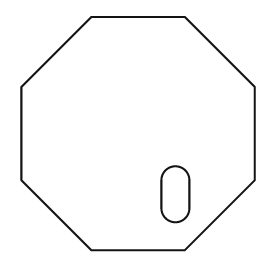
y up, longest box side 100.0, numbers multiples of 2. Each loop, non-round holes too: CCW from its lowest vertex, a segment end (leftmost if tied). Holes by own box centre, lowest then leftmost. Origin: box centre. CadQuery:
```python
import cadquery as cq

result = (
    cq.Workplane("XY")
    .moveTo(-20.0, -50.0)
    .lineTo(20.0, -50.0)
    .lineTo(50.0, -20.0)
    .lineTo(50.0, 20.0)
    .lineTo(20.0, 50.0)
    .lineTo(-20.0, 50.0)
    .lineTo(-50.0, 20.0)
    .lineTo(-50.0, -20.0)
    .close()
    .moveTo(10.0, -32.0)
    .threePointArc((16.0, -38.0), (22.0, -32.0))
    .lineTo(22.0, -20.0)
    .threePointArc((16.0, -14.0), (10.0, -20.0))
    .close()
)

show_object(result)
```